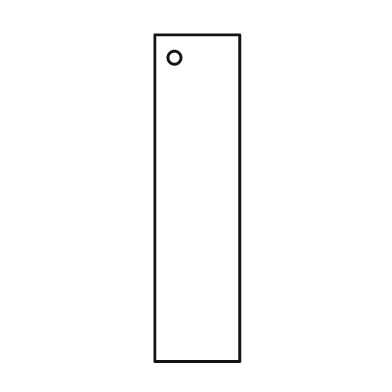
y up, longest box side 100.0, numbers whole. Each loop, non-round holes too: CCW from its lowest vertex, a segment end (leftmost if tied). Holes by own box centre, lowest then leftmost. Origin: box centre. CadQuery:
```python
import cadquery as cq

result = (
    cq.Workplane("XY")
    .moveTo(-13.0, -50.0)
    .lineTo(13.0, -50.0)
    .lineTo(13.0, 50.0)
    .lineTo(-13.0, 50.0)
    .close()
    .moveTo(-7.0, 43.0)
    .circle(2.0)
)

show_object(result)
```